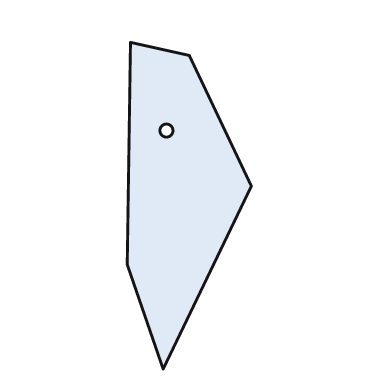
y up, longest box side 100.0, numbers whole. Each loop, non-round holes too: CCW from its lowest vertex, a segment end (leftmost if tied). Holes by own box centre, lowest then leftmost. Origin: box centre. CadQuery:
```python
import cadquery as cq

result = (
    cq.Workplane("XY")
    .moveTo(-8.0, -50.0)
    .lineTo(19.0, 6.0)
    .lineTo(0.0, 46.0)
    .lineTo(-18.0, 50.0)
    .lineTo(-19.0, -18.0)
    .close()
    .moveTo(-7.0, 23.0)
    .circle(2.0)
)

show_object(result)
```